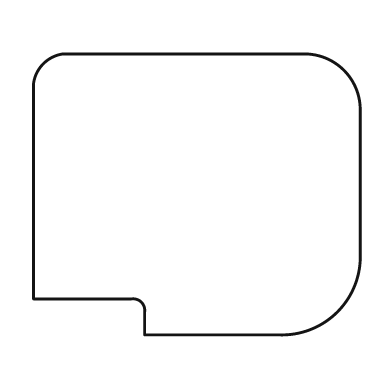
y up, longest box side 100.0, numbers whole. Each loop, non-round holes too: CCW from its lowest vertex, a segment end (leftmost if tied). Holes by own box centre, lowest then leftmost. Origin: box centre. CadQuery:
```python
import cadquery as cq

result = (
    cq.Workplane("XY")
    .moveTo(-16.0, -43.0)
    .lineTo(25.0, -43.0)
    .threePointArc((43.0, -36.0), (50.0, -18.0))
    .lineTo(50.0, 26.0)
    .threePointArc((45.0, 38.0), (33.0, 43.0))
    .lineTo(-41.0, 43.0)
    .threePointArc((-47.0, 40.0), (-50.0, 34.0))
    .lineTo(-50.0, -32.0)
    .lineTo(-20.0, -32.0)
    .threePointArc((-17.0, -33.0), (-16.0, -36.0))
    .close()
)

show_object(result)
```